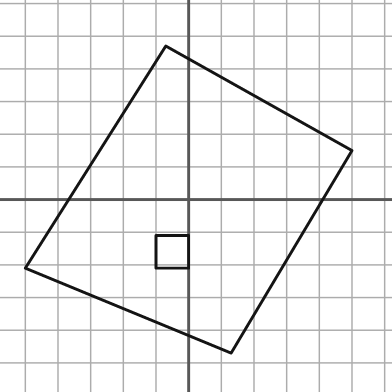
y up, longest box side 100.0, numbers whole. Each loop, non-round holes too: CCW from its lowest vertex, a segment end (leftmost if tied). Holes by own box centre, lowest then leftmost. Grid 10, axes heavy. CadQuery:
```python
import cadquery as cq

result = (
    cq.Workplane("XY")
    .moveTo(13.0, -47.0)
    .lineTo(50.0, 15.0)
    .lineTo(-7.0, 47.0)
    .lineTo(-50.0, -21.0)
    .close()
    .moveTo(-10.0, -21.0)
    .lineTo(0.0, -21.0)
    .lineTo(0.0, -11.0)
    .lineTo(-10.0, -11.0)
    .close()
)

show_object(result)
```